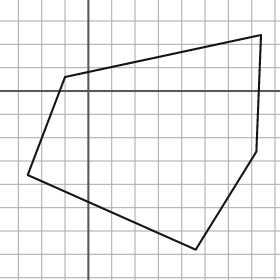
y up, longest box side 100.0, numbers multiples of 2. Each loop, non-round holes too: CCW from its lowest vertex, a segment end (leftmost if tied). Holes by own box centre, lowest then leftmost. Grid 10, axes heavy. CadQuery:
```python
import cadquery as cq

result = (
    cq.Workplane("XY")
    .moveTo(46.0, -68.0)
    .lineTo(72.0, -26.0)
    .lineTo(74.0, 24.0)
    .lineTo(-10.0, 6.0)
    .lineTo(-26.0, -36.0)
    .close()
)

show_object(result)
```